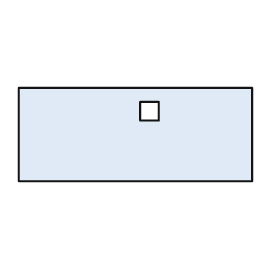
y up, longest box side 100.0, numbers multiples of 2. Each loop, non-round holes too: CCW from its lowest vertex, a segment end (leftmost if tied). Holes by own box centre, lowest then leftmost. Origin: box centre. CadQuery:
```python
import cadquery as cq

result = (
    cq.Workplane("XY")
    .moveTo(-50.0, -20.0)
    .lineTo(50.0, -20.0)
    .lineTo(50.0, 20.0)
    .lineTo(-50.0, 20.0)
    .close()
    .moveTo(2.0, 6.0)
    .lineTo(10.0, 6.0)
    .lineTo(10.0, 14.0)
    .lineTo(2.0, 14.0)
    .close()
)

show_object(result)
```